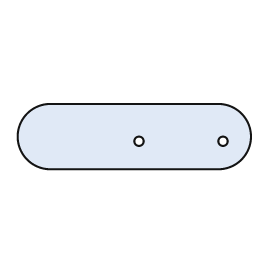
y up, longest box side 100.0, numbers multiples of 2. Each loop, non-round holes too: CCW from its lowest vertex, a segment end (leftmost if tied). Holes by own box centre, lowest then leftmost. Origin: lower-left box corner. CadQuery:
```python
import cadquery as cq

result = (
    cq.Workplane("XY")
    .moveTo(14.0, 0.0)
    .lineTo(86.0, 0.0)
    .threePointArc((100.0, 14.0), (86.0, 28.0))
    .lineTo(14.0, 28.0)
    .threePointArc((0.0, 14.0), (14.0, 0.0))
    .close()
    .moveTo(52.0, 12.0)
    .circle(2.0)
    .moveTo(88.0, 12.0)
    .circle(2.0)
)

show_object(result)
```